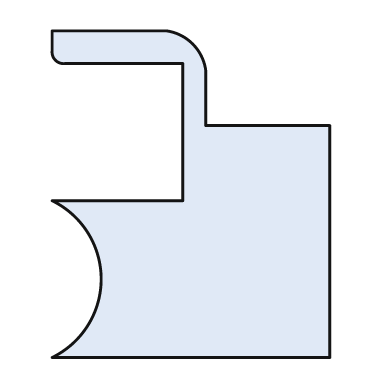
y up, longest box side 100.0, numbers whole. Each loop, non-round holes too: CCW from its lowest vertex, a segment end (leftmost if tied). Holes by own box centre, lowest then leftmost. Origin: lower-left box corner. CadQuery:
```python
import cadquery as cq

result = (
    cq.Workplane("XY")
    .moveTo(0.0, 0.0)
    .lineTo(85.0, 0.0)
    .lineTo(85.0, 71.0)
    .lineTo(47.0, 71.0)
    .lineTo(47.0, 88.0)
    .threePointArc((43.0, 96.0), (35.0, 100.0))
    .lineTo(0.0, 100.0)
    .lineTo(0.0, 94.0)
    .threePointArc((1.0, 91.0), (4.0, 90.0))
    .lineTo(40.0, 90.0)
    .lineTo(40.0, 48.0)
    .lineTo(0.0, 48.0)
    .threePointArc((15.0, 24.0), (0.0, 0.0))
    .close()
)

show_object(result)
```